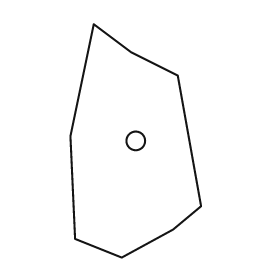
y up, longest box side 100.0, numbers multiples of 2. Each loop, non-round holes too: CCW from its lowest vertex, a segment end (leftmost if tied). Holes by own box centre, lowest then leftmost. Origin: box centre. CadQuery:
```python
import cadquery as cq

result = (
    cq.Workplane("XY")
    .moveTo(-6.0, -50.0)
    .lineTo(16.0, -38.0)
    .lineTo(28.0, -28.0)
    .lineTo(18.0, 28.0)
    .lineTo(-2.0, 38.0)
    .lineTo(-18.0, 50.0)
    .lineTo(-28.0, 2.0)
    .lineTo(-26.0, -42.0)
    .close()
    .moveTo(0.0, 0.0)
    .circle(4.0)
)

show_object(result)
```